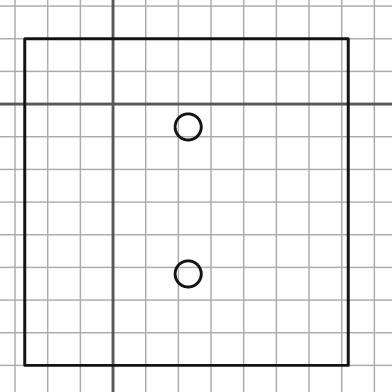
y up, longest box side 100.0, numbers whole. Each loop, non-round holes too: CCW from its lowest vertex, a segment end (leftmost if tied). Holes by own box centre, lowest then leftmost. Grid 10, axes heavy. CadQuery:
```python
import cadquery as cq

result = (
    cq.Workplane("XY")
    .moveTo(-27.0, -80.0)
    .lineTo(72.0, -80.0)
    .lineTo(72.0, 20.0)
    .lineTo(-27.0, 20.0)
    .close()
    .moveTo(23.0, -52.0)
    .circle(4.0)
    .moveTo(23.0, -7.0)
    .circle(4.0)
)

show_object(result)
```